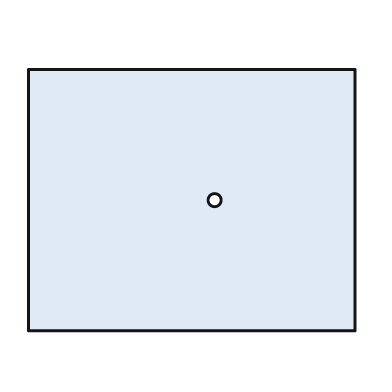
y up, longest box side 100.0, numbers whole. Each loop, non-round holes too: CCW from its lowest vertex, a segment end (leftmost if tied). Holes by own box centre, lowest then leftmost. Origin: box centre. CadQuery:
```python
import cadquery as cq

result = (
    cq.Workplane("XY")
    .moveTo(-50.0, -40.0)
    .lineTo(50.0, -40.0)
    .lineTo(50.0, 40.0)
    .lineTo(-50.0, 40.0)
    .close()
    .moveTo(7.0, 0.0)
    .circle(2.0)
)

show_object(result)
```